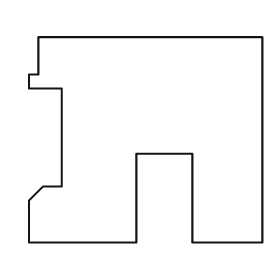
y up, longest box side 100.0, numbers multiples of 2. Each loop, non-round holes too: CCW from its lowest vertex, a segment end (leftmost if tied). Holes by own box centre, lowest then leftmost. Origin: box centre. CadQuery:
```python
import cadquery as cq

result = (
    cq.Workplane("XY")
    .moveTo(-50.0, -44.0)
    .lineTo(-4.0, -44.0)
    .lineTo(-4.0, -6.0)
    .lineTo(20.0, -6.0)
    .lineTo(20.0, -44.0)
    .lineTo(50.0, -44.0)
    .lineTo(50.0, 44.0)
    .lineTo(-46.0, 44.0)
    .lineTo(-46.0, 28.0)
    .lineTo(-50.0, 28.0)
    .lineTo(-50.0, 22.0)
    .lineTo(-36.0, 22.0)
    .lineTo(-36.0, -20.0)
    .lineTo(-44.0, -20.0)
    .lineTo(-50.0, -26.0)
    .close()
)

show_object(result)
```